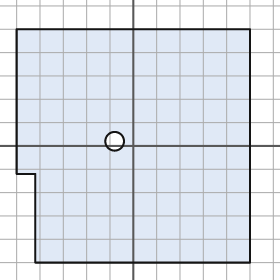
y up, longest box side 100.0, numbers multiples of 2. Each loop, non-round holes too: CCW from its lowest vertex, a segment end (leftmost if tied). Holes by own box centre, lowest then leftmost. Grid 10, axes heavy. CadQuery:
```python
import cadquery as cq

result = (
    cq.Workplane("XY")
    .moveTo(-42.0, -50.0)
    .lineTo(50.0, -50.0)
    .lineTo(50.0, 50.0)
    .lineTo(-50.0, 50.0)
    .lineTo(-50.0, -12.0)
    .lineTo(-42.0, -12.0)
    .close()
    .moveTo(-8.0, 2.0)
    .circle(4.0)
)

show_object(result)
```